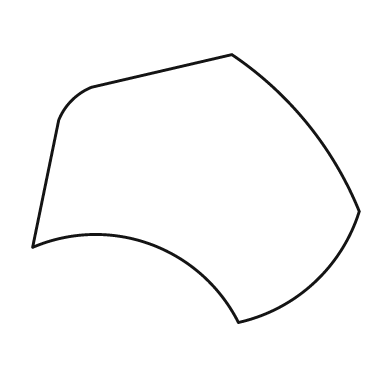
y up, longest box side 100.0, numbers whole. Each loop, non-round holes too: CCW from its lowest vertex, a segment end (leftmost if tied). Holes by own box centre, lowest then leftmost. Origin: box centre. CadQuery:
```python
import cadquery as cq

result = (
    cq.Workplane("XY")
    .moveTo(13.0, -41.0)
    .threePointArc((36.0, -29.0), (50.0, -7.0))
    .threePointArc((34.0, 20.0), (11.0, 41.0))
    .lineTo(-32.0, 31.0)
    .threePointArc((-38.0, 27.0), (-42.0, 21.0))
    .lineTo(-50.0, -18.0)
    .threePointArc((-14.0, -17.0), (13.0, -41.0))
    .close()
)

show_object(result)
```